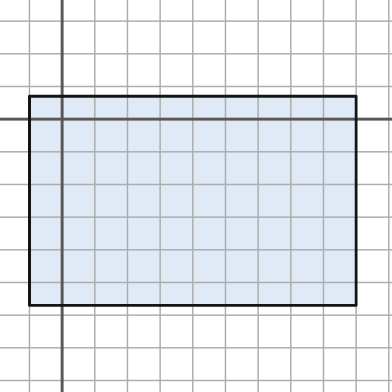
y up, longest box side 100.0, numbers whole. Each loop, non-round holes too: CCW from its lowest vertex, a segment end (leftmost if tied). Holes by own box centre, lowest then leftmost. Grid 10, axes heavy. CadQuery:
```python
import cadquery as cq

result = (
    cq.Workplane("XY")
    .moveTo(-10.0, -57.0)
    .lineTo(90.0, -57.0)
    .lineTo(90.0, 7.0)
    .lineTo(-10.0, 7.0)
    .close()
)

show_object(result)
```